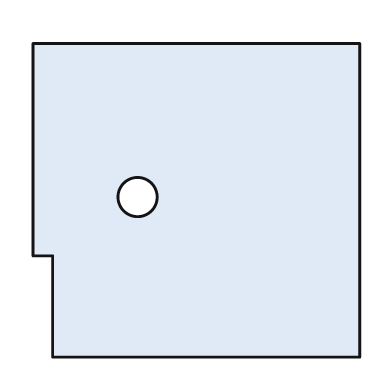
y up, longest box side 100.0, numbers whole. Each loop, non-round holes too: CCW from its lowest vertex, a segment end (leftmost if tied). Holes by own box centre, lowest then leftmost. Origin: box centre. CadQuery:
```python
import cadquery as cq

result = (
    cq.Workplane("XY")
    .moveTo(-44.0, -48.0)
    .lineTo(50.0, -48.0)
    .lineTo(50.0, 48.0)
    .lineTo(-50.0, 48.0)
    .lineTo(-50.0, -17.0)
    .lineTo(-44.0, -17.0)
    .close()
    .moveTo(-18.0, 1.0)
    .circle(6.0)
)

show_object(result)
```